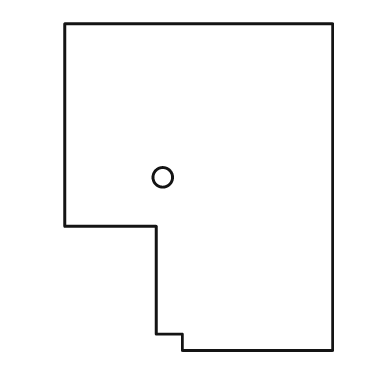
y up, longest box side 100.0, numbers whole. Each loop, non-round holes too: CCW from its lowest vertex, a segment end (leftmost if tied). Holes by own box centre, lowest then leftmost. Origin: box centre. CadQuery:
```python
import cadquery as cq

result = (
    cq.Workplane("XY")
    .moveTo(-5.0, -50.0)
    .lineTo(41.0, -50.0)
    .lineTo(41.0, 50.0)
    .lineTo(-41.0, 50.0)
    .lineTo(-41.0, -12.0)
    .lineTo(-13.0, -12.0)
    .lineTo(-13.0, -45.0)
    .lineTo(-5.0, -45.0)
    .close()
    .moveTo(-11.0, 3.0)
    .circle(3.0)
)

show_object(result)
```